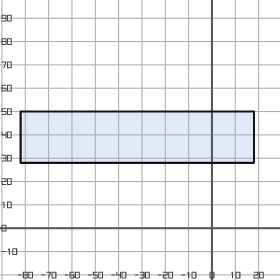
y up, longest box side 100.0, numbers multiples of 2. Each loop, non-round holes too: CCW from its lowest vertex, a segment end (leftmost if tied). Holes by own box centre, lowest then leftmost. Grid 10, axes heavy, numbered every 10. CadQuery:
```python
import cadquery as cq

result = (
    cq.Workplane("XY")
    .moveTo(-82.0, 28.0)
    .lineTo(18.0, 28.0)
    .lineTo(18.0, 50.0)
    .lineTo(-82.0, 50.0)
    .close()
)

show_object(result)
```